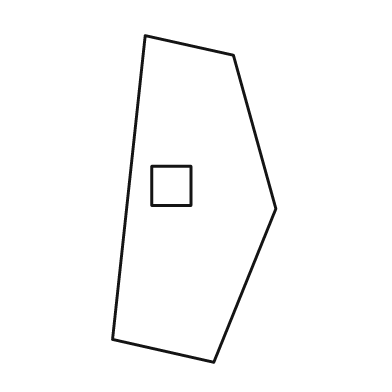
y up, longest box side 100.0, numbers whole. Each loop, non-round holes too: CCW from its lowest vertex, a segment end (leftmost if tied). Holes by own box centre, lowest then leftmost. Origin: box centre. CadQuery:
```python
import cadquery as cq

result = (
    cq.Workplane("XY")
    .moveTo(6.0, -50.0)
    .lineTo(25.0, -3.0)
    .lineTo(12.0, 44.0)
    .lineTo(-15.0, 50.0)
    .lineTo(-25.0, -43.0)
    .close()
    .moveTo(-13.0, -2.0)
    .lineTo(-1.0, -2.0)
    .lineTo(-1.0, 10.0)
    .lineTo(-13.0, 10.0)
    .close()
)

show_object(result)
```